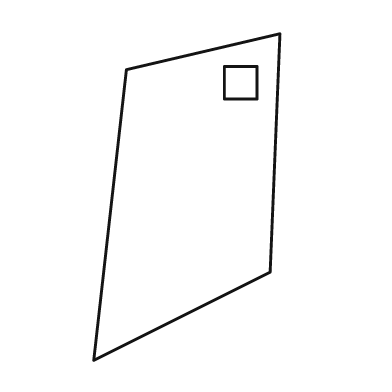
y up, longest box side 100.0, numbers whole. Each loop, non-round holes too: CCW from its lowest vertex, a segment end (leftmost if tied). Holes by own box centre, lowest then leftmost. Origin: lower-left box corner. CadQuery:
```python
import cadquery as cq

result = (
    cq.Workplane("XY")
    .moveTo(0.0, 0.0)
    .lineTo(54.0, 27.0)
    .lineTo(57.0, 100.0)
    .lineTo(10.0, 89.0)
    .close()
    .moveTo(40.0, 80.0)
    .lineTo(50.0, 80.0)
    .lineTo(50.0, 90.0)
    .lineTo(40.0, 90.0)
    .close()
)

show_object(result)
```